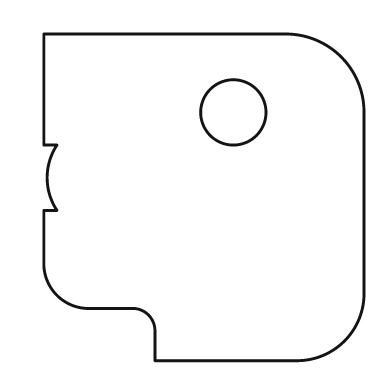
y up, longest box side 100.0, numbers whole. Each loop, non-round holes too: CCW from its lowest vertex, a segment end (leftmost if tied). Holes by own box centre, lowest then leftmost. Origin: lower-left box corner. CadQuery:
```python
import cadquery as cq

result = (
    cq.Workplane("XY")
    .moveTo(34.0, 0.0)
    .lineTo(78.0, 0.0)
    .threePointArc((92.0, 6.0), (98.0, 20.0))
    .lineTo(98.0, 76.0)
    .threePointArc((91.0, 93.0), (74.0, 100.0))
    .lineTo(0.0, 100.0)
    .lineTo(0.0, 66.0)
    .lineTo(4.0, 66.0)
    .threePointArc((1.0, 56.0), (4.0, 46.0))
    .lineTo(0.0, 46.0)
    .lineTo(0.0, 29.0)
    .threePointArc((4.0, 20.0), (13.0, 16.0))
    .lineTo(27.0, 16.0)
    .threePointArc((32.0, 14.0), (34.0, 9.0))
    .close()
    .moveTo(58.0, 76.0)
    .circle(10.0)
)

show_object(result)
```